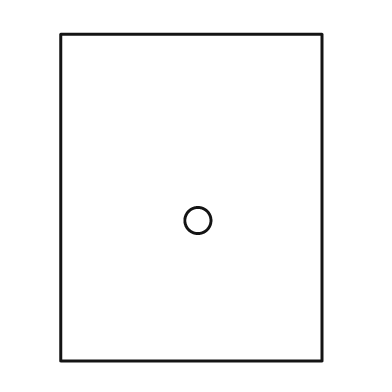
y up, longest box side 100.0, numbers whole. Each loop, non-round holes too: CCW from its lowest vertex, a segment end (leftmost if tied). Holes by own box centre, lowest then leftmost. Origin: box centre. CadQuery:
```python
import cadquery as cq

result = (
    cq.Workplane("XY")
    .moveTo(-40.0, -50.0)
    .lineTo(40.0, -50.0)
    .lineTo(40.0, 50.0)
    .lineTo(-40.0, 50.0)
    .close()
    .moveTo(2.0, -7.0)
    .circle(4.0)
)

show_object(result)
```